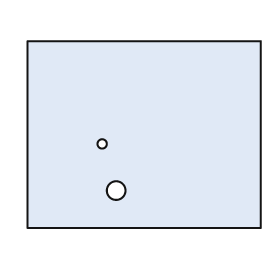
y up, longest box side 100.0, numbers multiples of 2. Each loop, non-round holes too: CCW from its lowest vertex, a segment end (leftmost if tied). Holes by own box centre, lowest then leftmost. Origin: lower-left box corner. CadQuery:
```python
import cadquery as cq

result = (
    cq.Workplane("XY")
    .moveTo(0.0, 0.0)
    .lineTo(100.0, 0.0)
    .lineTo(100.0, 80.0)
    .lineTo(0.0, 80.0)
    .close()
    .moveTo(38.0, 16.0)
    .circle(4.0)
    .moveTo(32.0, 36.0)
    .circle(2.0)
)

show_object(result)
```